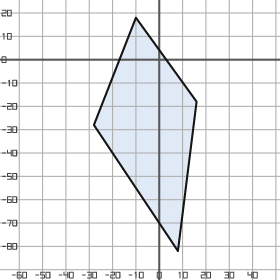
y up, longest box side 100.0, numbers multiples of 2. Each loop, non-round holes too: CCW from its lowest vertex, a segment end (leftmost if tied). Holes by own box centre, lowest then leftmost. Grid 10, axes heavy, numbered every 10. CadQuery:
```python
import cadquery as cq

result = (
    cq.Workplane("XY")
    .moveTo(8.0, -82.0)
    .lineTo(16.0, -18.0)
    .lineTo(-10.0, 18.0)
    .lineTo(-28.0, -28.0)
    .close()
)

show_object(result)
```